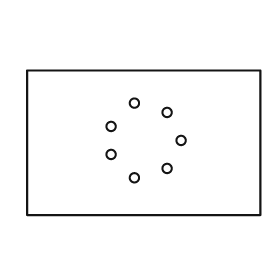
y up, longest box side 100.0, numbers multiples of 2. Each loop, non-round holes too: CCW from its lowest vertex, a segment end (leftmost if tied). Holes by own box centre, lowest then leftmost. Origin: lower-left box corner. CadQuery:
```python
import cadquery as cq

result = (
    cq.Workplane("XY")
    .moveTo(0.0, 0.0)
    .lineTo(100.0, 0.0)
    .lineTo(100.0, 62.0)
    .lineTo(0.0, 62.0)
    .close()
    .moveTo(46.0, 16.0)
    .circle(2.0)
    .moveTo(60.0, 20.0)
    .circle(2.0)
    .moveTo(36.0, 26.0)
    .circle(2.0)
    .moveTo(66.0, 32.0)
    .circle(2.0)
    .moveTo(36.0, 38.0)
    .circle(2.0)
    .moveTo(60.0, 44.0)
    .circle(2.0)
    .moveTo(46.0, 48.0)
    .circle(2.0)
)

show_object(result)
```